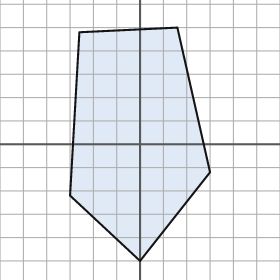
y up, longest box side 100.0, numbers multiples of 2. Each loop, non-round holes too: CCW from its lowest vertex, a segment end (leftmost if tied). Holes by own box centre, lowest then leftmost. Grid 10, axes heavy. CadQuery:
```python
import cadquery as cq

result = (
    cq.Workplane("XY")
    .moveTo(0.0, -50.0)
    .lineTo(30.0, -12.0)
    .lineTo(16.0, 50.0)
    .lineTo(-26.0, 48.0)
    .lineTo(-30.0, -22.0)
    .close()
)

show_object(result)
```